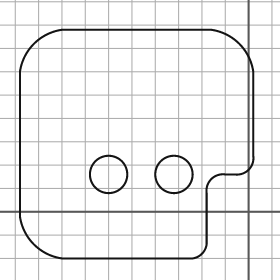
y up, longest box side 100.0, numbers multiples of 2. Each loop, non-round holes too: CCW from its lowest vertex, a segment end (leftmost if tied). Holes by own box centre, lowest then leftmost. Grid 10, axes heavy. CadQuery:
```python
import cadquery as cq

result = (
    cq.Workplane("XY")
    .moveTo(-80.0, -20.0)
    .lineTo(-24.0, -20.0)
    .threePointArc((-20.0, -18.0), (-18.0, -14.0))
    .lineTo(-18.0, 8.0)
    .threePointArc((-16.0, 14.0), (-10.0, 16.0))
    .lineTo(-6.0, 16.0)
    .threePointArc((0.0, 18.0), (2.0, 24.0))
    .lineTo(2.0, 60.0)
    .threePointArc((-4.0, 72.0), (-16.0, 78.0))
    .lineTo(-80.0, 78.0)
    .threePointArc((-92.0, 72.0), (-98.0, 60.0))
    .lineTo(-98.0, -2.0)
    .threePointArc((-92.0, -14.0), (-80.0, -20.0))
    .close()
    .moveTo(-60.0, 16.0)
    .circle(8.0)
    .moveTo(-32.0, 16.0)
    .circle(8.0)
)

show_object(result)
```